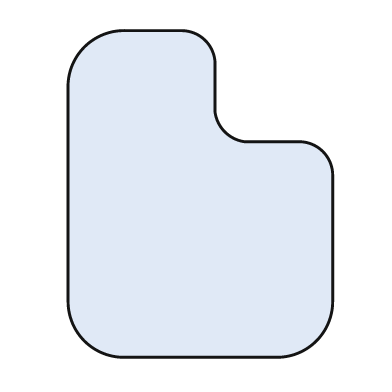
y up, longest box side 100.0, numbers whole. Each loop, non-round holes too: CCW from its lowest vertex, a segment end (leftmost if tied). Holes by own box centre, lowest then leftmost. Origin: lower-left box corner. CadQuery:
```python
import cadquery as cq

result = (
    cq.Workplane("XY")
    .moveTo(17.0, 0.0)
    .lineTo(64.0, 0.0)
    .threePointArc((76.0, 5.0), (81.0, 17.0))
    .lineTo(81.0, 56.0)
    .threePointArc((78.0, 63.0), (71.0, 66.0))
    .lineTo(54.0, 66.0)
    .threePointArc((48.0, 69.0), (45.0, 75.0))
    .lineTo(45.0, 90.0)
    .threePointArc((42.0, 97.0), (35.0, 100.0))
    .lineTo(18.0, 100.0)
    .threePointArc((5.0, 95.0), (0.0, 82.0))
    .lineTo(0.0, 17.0)
    .threePointArc((5.0, 5.0), (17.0, 0.0))
    .close()
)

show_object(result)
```